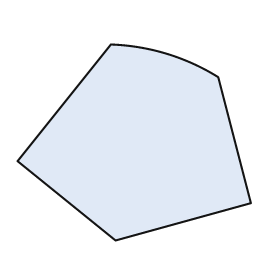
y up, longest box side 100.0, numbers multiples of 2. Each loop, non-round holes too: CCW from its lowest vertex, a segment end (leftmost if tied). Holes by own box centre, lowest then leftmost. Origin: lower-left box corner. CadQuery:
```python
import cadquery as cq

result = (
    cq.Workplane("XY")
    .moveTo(42.0, 0.0)
    .lineTo(100.0, 16.0)
    .lineTo(86.0, 70.0)
    .threePointArc((64.0, 80.0), (40.0, 84.0))
    .lineTo(0.0, 34.0)
    .close()
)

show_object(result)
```